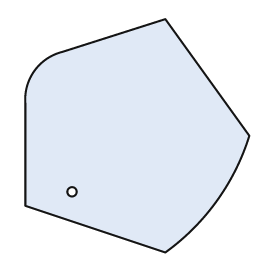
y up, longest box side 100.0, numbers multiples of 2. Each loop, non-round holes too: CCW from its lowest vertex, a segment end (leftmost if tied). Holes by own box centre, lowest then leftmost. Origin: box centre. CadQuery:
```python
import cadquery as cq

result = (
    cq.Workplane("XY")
    .moveTo(12.0, -50.0)
    .threePointArc((34.0, -28.0), (48.0, 0.0))
    .lineTo(12.0, 50.0)
    .lineTo(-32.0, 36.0)
    .threePointArc((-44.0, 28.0), (-48.0, 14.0))
    .lineTo(-48.0, -30.0)
    .close()
    .moveTo(-28.0, -24.0)
    .circle(2.0)
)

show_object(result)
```